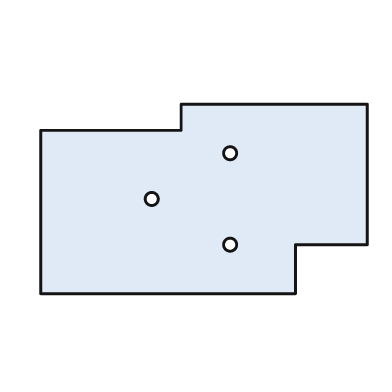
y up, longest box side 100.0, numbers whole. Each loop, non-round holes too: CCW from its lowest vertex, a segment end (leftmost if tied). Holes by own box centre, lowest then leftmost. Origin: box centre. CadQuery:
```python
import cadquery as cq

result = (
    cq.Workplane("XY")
    .moveTo(-50.0, -29.0)
    .lineTo(28.0, -29.0)
    .lineTo(28.0, -14.0)
    .lineTo(50.0, -14.0)
    .lineTo(50.0, 29.0)
    .lineTo(-7.0, 29.0)
    .lineTo(-7.0, 21.0)
    .lineTo(-50.0, 21.0)
    .close()
    .moveTo(8.0, -14.0)
    .circle(2.0)
    .moveTo(-16.0, 0.0)
    .circle(2.0)
    .moveTo(8.0, 14.0)
    .circle(2.0)
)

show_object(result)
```